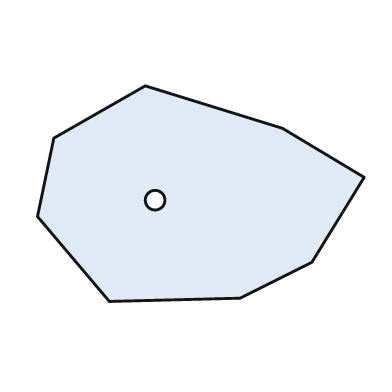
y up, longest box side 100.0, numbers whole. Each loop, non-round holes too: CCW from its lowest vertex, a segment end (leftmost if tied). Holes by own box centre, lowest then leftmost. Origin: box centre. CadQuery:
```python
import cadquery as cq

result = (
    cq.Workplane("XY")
    .moveTo(-28.0, -33.0)
    .lineTo(12.0, -32.0)
    .lineTo(34.0, -21.0)
    .lineTo(50.0, 5.0)
    .lineTo(25.0, 20.0)
    .lineTo(-17.0, 33.0)
    .lineTo(-45.0, 17.0)
    .lineTo(-50.0, -7.0)
    .close()
    .moveTo(-14.0, -2.0)
    .circle(3.0)
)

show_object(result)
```